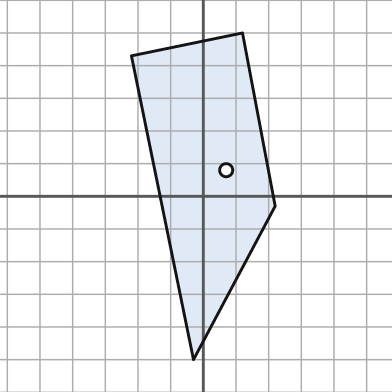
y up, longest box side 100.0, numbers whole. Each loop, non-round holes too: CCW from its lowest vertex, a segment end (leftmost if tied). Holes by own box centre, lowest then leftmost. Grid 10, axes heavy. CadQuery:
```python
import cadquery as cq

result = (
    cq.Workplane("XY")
    .moveTo(-3.0, -50.0)
    .lineTo(22.0, -3.0)
    .lineTo(12.0, 50.0)
    .lineTo(-22.0, 43.0)
    .close()
    .moveTo(7.0, 8.0)
    .circle(2.0)
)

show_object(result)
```